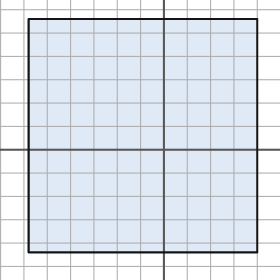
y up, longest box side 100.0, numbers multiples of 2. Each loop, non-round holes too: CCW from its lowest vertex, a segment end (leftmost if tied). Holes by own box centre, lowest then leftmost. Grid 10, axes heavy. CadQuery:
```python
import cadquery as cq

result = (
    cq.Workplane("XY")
    .moveTo(-58.0, -44.0)
    .lineTo(40.0, -44.0)
    .lineTo(40.0, 56.0)
    .lineTo(-58.0, 56.0)
    .close()
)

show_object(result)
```